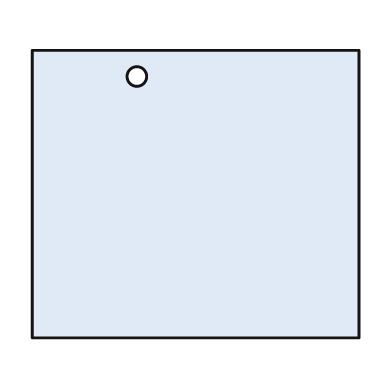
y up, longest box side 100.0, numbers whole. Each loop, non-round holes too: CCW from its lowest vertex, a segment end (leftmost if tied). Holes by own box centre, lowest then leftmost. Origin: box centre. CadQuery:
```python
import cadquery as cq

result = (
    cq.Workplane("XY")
    .moveTo(-50.0, -44.0)
    .lineTo(50.0, -44.0)
    .lineTo(50.0, 44.0)
    .lineTo(-50.0, 44.0)
    .close()
    .moveTo(-18.0, 36.0)
    .circle(3.0)
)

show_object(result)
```